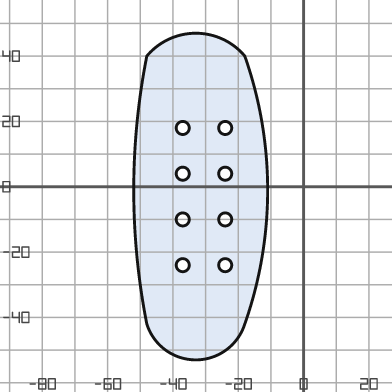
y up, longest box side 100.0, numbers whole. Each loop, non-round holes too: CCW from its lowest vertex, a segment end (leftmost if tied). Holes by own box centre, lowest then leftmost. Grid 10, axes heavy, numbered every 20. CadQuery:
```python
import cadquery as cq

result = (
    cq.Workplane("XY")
    .moveTo(-48.0, -42.0)
    .threePointArc((-33.0, -53.0), (-18.0, -42.0))
    .threePointArc((-11.0, -1.0), (-18.0, 40.0))
    .threePointArc((-33.0, 47.0), (-48.0, 40.0))
    .threePointArc((-52.0, -1.0), (-48.0, -42.0))
    .close()
    .moveTo(-37.0, -24.0)
    .circle(2.0)
    .moveTo(-24.0, -24.0)
    .circle(2.0)
    .moveTo(-37.0, -10.0)
    .circle(2.0)
    .moveTo(-24.0, -10.0)
    .circle(2.0)
    .moveTo(-37.0, 4.0)
    .circle(2.0)
    .moveTo(-24.0, 4.0)
    .circle(2.0)
    .moveTo(-37.0, 18.0)
    .circle(2.0)
    .moveTo(-24.0, 18.0)
    .circle(2.0)
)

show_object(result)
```